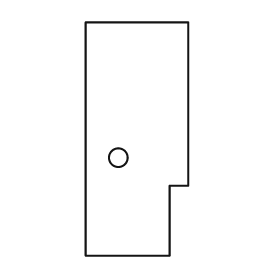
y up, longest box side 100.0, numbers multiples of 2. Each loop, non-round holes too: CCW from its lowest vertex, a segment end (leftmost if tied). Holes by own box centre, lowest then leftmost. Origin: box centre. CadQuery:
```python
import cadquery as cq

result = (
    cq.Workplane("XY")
    .moveTo(-22.0, -50.0)
    .lineTo(14.0, -50.0)
    .lineTo(14.0, -20.0)
    .lineTo(22.0, -20.0)
    .lineTo(22.0, 50.0)
    .lineTo(-22.0, 50.0)
    .close()
    .moveTo(-8.0, -8.0)
    .circle(4.0)
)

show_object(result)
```